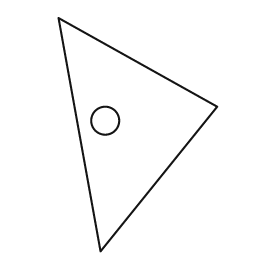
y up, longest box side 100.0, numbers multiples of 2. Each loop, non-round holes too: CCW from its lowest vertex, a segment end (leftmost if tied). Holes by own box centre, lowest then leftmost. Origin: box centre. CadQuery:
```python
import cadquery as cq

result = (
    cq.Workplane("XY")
    .moveTo(-16.0, -50.0)
    .lineTo(34.0, 12.0)
    .lineTo(-34.0, 50.0)
    .close()
    .moveTo(-14.0, 6.0)
    .circle(6.0)
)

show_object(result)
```